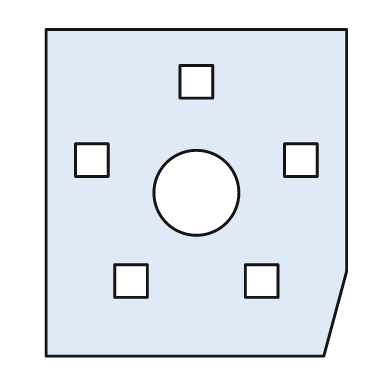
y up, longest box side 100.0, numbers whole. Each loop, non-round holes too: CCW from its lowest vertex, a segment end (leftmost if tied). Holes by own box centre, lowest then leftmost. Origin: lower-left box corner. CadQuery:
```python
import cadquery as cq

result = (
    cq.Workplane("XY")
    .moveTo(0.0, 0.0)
    .lineTo(85.0, 0.0)
    .lineTo(92.0, 26.0)
    .lineTo(92.0, 100.0)
    .lineTo(0.0, 100.0)
    .close()
    .moveTo(21.0, 18.0)
    .lineTo(31.0, 18.0)
    .lineTo(31.0, 28.0)
    .lineTo(21.0, 28.0)
    .close()
    .moveTo(61.0, 18.0)
    .lineTo(71.0, 18.0)
    .lineTo(71.0, 28.0)
    .lineTo(61.0, 28.0)
    .close()
    .moveTo(46.0, 50.0)
    .circle(13.0)
    .moveTo(9.0, 55.0)
    .lineTo(19.0, 55.0)
    .lineTo(19.0, 65.0)
    .lineTo(9.0, 65.0)
    .close()
    .moveTo(73.0, 55.0)
    .lineTo(83.0, 55.0)
    .lineTo(83.0, 65.0)
    .lineTo(73.0, 65.0)
    .close()
    .moveTo(41.0, 79.0)
    .lineTo(51.0, 79.0)
    .lineTo(51.0, 89.0)
    .lineTo(41.0, 89.0)
    .close()
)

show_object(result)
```